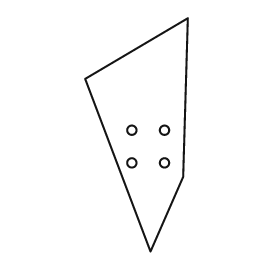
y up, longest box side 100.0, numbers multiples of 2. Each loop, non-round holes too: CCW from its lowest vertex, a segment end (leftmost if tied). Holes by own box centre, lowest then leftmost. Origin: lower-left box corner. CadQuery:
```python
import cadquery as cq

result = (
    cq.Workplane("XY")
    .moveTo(28.0, 0.0)
    .lineTo(42.0, 32.0)
    .lineTo(44.0, 100.0)
    .lineTo(0.0, 74.0)
    .close()
    .moveTo(20.0, 38.0)
    .circle(2.0)
    .moveTo(34.0, 38.0)
    .circle(2.0)
    .moveTo(20.0, 52.0)
    .circle(2.0)
    .moveTo(34.0, 52.0)
    .circle(2.0)
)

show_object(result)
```